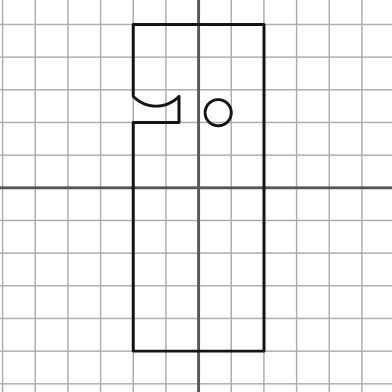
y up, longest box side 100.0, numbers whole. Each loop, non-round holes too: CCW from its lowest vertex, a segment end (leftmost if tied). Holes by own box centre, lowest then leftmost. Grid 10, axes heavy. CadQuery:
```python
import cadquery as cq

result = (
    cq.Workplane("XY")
    .moveTo(-20.0, -50.0)
    .lineTo(20.0, -50.0)
    .lineTo(20.0, 50.0)
    .lineTo(-20.0, 50.0)
    .lineTo(-20.0, 28.0)
    .threePointArc((-13.0, 25.0), (-6.0, 28.0))
    .lineTo(-6.0, 20.0)
    .lineTo(-20.0, 20.0)
    .close()
    .moveTo(6.0, 23.0)
    .circle(4.0)
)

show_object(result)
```